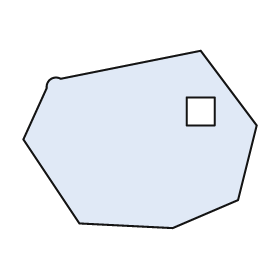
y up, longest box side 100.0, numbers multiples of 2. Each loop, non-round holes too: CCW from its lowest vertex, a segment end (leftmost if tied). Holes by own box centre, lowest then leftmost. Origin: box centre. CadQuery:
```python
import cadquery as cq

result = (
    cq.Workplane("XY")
    .moveTo(14.0, -38.0)
    .lineTo(42.0, -26.0)
    .lineTo(50.0, 6.0)
    .lineTo(26.0, 38.0)
    .lineTo(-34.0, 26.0)
    .threePointArc((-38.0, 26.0), (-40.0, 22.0))
    .lineTo(-50.0, 0.0)
    .lineTo(-26.0, -36.0)
    .close()
    .moveTo(20.0, 6.0)
    .lineTo(32.0, 6.0)
    .lineTo(32.0, 18.0)
    .lineTo(20.0, 18.0)
    .close()
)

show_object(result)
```